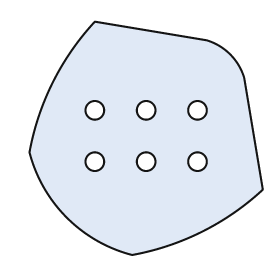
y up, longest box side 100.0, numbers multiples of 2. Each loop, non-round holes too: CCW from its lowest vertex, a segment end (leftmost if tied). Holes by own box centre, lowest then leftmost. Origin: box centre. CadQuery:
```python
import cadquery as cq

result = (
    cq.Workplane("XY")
    .moveTo(-6.0, -50.0)
    .threePointArc((24.0, -40.0), (50.0, -22.0))
    .lineTo(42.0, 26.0)
    .threePointArc((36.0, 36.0), (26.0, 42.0))
    .lineTo(-22.0, 50.0)
    .threePointArc((-40.0, 24.0), (-50.0, -6.0))
    .threePointArc((-34.0, -34.0), (-6.0, -50.0))
    .close()
    .moveTo(-22.0, -10.0)
    .circle(4.0)
    .moveTo(0.0, -10.0)
    .circle(4.0)
    .moveTo(22.0, -10.0)
    .circle(4.0)
    .moveTo(-22.0, 12.0)
    .circle(4.0)
    .moveTo(0.0, 12.0)
    .circle(4.0)
    .moveTo(22.0, 12.0)
    .circle(4.0)
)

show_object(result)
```